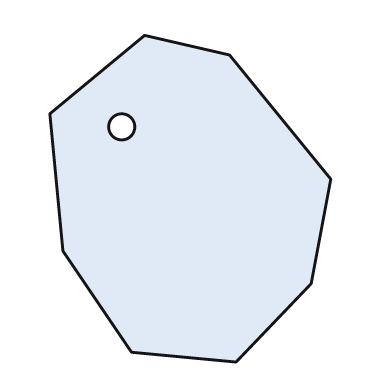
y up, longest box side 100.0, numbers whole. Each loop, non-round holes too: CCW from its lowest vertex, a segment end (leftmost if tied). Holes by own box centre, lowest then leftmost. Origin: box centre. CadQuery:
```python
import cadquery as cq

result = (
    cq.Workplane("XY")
    .moveTo(14.0, -50.0)
    .lineTo(37.0, -26.0)
    .lineTo(43.0, 6.0)
    .lineTo(12.0, 44.0)
    .lineTo(-14.0, 50.0)
    .lineTo(-43.0, 26.0)
    .lineTo(-39.0, -16.0)
    .lineTo(-18.0, -47.0)
    .close()
    .moveTo(-21.0, 22.0)
    .circle(4.0)
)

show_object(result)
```